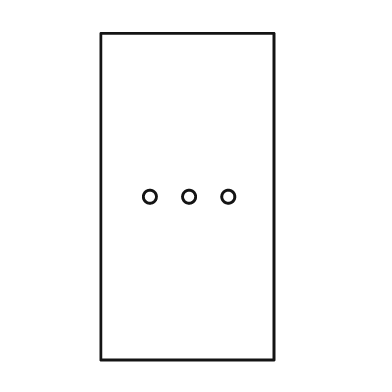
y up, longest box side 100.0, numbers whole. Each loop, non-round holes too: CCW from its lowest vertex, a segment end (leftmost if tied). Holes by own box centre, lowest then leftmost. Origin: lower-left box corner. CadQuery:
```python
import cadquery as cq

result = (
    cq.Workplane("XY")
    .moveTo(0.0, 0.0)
    .lineTo(53.0, 0.0)
    .lineTo(53.0, 100.0)
    .lineTo(0.0, 100.0)
    .close()
    .moveTo(15.0, 50.0)
    .circle(2.0)
    .moveTo(27.0, 50.0)
    .circle(2.0)
    .moveTo(39.0, 50.0)
    .circle(2.0)
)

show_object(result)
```